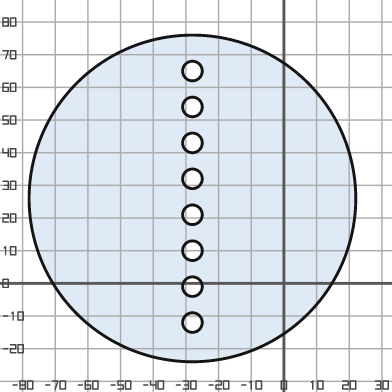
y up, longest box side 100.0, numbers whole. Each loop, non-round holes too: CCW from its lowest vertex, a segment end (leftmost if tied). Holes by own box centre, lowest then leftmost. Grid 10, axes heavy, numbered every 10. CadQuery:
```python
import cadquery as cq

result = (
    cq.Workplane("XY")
    .moveTo(-28.0, 26.0)
    .circle(50.0)
    .moveTo(-28.0, -12.0)
    .circle(3.0)
    .moveTo(-28.0, -1.0)
    .circle(3.0)
    .moveTo(-28.0, 10.0)
    .circle(3.0)
    .moveTo(-28.0, 21.0)
    .circle(3.0)
    .moveTo(-28.0, 32.0)
    .circle(3.0)
    .moveTo(-28.0, 43.0)
    .circle(3.0)
    .moveTo(-28.0, 54.0)
    .circle(3.0)
    .moveTo(-28.0, 65.0)
    .circle(3.0)
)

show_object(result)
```